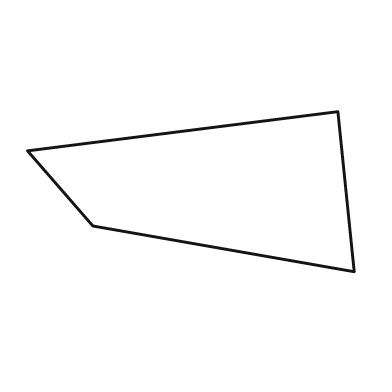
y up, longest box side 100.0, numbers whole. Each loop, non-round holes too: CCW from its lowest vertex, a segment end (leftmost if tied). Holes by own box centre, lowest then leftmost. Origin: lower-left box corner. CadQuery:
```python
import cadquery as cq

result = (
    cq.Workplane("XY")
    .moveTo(100.0, 0.0)
    .lineTo(95.0, 49.0)
    .lineTo(0.0, 37.0)
    .lineTo(20.0, 14.0)
    .close()
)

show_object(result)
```